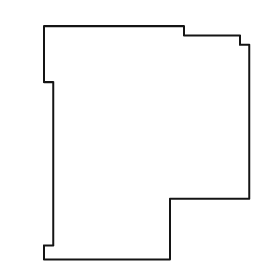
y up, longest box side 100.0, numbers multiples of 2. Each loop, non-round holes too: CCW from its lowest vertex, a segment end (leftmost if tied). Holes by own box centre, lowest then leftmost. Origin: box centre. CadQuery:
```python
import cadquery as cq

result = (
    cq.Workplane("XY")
    .moveTo(-44.0, -50.0)
    .lineTo(10.0, -50.0)
    .lineTo(10.0, -24.0)
    .lineTo(44.0, -24.0)
    .lineTo(44.0, 42.0)
    .lineTo(40.0, 42.0)
    .lineTo(40.0, 46.0)
    .lineTo(16.0, 46.0)
    .lineTo(16.0, 50.0)
    .lineTo(-44.0, 50.0)
    .lineTo(-44.0, 26.0)
    .lineTo(-40.0, 26.0)
    .lineTo(-40.0, -44.0)
    .lineTo(-44.0, -44.0)
    .close()
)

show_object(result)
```